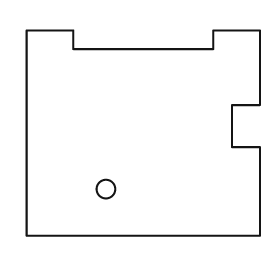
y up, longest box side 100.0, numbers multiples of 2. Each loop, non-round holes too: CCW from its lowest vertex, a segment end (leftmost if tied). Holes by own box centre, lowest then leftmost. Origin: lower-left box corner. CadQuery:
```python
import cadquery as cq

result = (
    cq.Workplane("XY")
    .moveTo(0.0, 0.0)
    .lineTo(100.0, 0.0)
    .lineTo(100.0, 38.0)
    .lineTo(88.0, 38.0)
    .lineTo(88.0, 56.0)
    .lineTo(100.0, 56.0)
    .lineTo(100.0, 88.0)
    .lineTo(80.0, 88.0)
    .lineTo(80.0, 80.0)
    .lineTo(20.0, 80.0)
    .lineTo(20.0, 88.0)
    .lineTo(0.0, 88.0)
    .close()
    .moveTo(34.0, 20.0)
    .circle(4.0)
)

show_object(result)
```